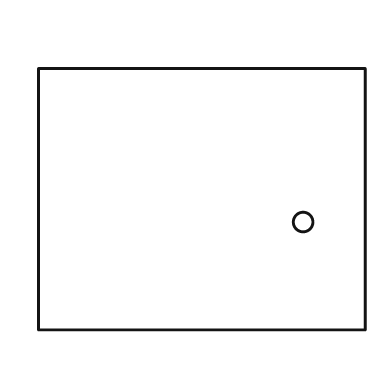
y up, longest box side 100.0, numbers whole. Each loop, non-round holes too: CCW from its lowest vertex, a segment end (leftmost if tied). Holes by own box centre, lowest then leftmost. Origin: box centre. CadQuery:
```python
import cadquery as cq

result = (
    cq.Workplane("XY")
    .moveTo(-50.0, -40.0)
    .lineTo(50.0, -40.0)
    .lineTo(50.0, 40.0)
    .lineTo(-50.0, 40.0)
    .close()
    .moveTo(31.0, -7.0)
    .circle(3.0)
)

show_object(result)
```